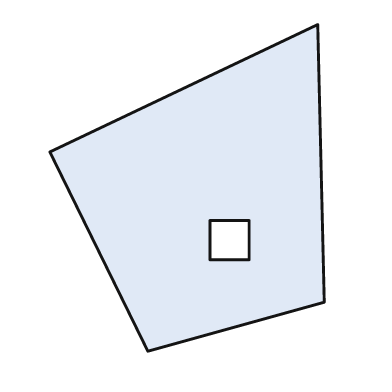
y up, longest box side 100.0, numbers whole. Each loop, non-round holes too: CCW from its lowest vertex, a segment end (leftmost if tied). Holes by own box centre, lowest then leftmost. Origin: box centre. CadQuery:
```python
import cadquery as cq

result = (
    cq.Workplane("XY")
    .moveTo(-12.0, -50.0)
    .lineTo(42.0, -35.0)
    .lineTo(40.0, 50.0)
    .lineTo(-42.0, 11.0)
    .close()
    .moveTo(7.0, -22.0)
    .lineTo(19.0, -22.0)
    .lineTo(19.0, -10.0)
    .lineTo(7.0, -10.0)
    .close()
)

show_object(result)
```